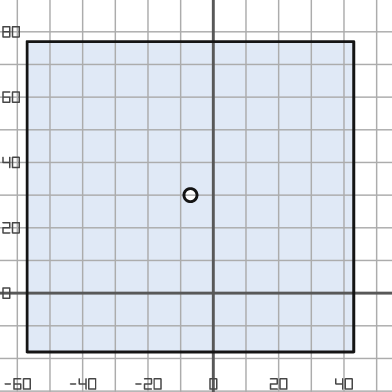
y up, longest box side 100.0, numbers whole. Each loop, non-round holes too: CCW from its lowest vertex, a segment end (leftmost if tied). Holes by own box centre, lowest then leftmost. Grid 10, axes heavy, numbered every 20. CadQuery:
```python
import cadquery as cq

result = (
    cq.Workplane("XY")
    .moveTo(-57.0, -18.0)
    .lineTo(43.0, -18.0)
    .lineTo(43.0, 77.0)
    .lineTo(-57.0, 77.0)
    .close()
    .moveTo(-7.0, 30.0)
    .circle(2.0)
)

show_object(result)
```